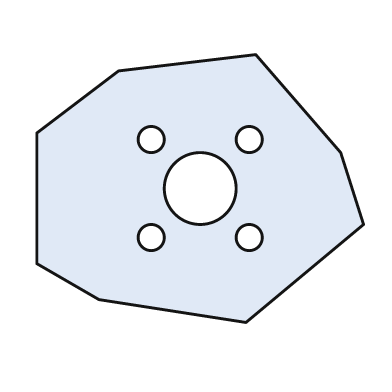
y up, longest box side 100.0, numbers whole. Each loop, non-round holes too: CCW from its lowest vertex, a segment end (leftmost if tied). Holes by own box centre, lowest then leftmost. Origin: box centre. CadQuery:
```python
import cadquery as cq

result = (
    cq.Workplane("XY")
    .moveTo(14.0, -41.0)
    .lineTo(50.0, -11.0)
    .lineTo(43.0, 11.0)
    .lineTo(17.0, 41.0)
    .lineTo(-25.0, 36.0)
    .lineTo(-50.0, 17.0)
    .lineTo(-50.0, -23.0)
    .lineTo(-31.0, -34.0)
    .close()
    .moveTo(-15.0, -15.0)
    .circle(4.0)
    .moveTo(15.0, -15.0)
    .circle(4.0)
    .moveTo(0.0, 0.0)
    .circle(11.0)
    .moveTo(-15.0, 15.0)
    .circle(4.0)
    .moveTo(15.0, 15.0)
    .circle(4.0)
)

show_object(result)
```